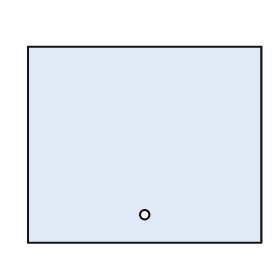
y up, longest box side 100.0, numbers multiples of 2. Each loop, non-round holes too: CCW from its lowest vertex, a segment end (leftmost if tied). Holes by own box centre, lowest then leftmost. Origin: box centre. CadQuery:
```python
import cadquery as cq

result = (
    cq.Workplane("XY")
    .moveTo(-50.0, -42.0)
    .lineTo(50.0, -42.0)
    .lineTo(50.0, 42.0)
    .lineTo(-50.0, 42.0)
    .close()
    .moveTo(0.0, -30.0)
    .circle(2.0)
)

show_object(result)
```